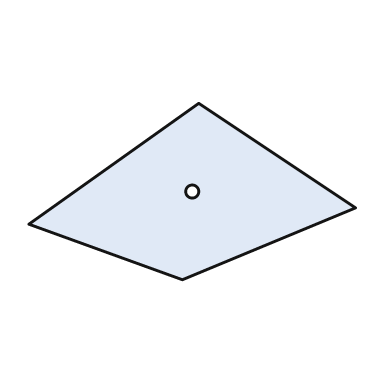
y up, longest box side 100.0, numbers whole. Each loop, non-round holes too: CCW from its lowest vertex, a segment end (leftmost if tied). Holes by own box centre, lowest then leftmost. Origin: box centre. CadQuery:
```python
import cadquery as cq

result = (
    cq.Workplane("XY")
    .moveTo(-3.0, -27.0)
    .lineTo(50.0, -5.0)
    .lineTo(2.0, 27.0)
    .lineTo(-50.0, -10.0)
    .close()
    .moveTo(0.0, 0.0)
    .circle(2.0)
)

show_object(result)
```